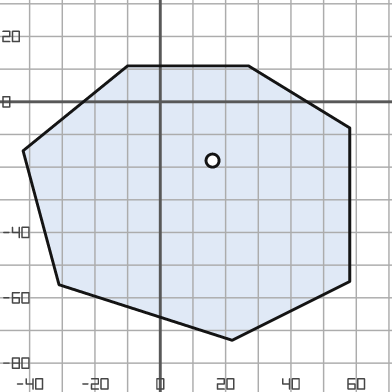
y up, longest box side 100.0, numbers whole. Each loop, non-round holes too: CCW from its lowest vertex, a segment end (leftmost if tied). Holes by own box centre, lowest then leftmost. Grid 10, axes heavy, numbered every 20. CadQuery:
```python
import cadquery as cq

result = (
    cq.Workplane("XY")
    .moveTo(22.0, -73.0)
    .lineTo(58.0, -55.0)
    .lineTo(58.0, -8.0)
    .lineTo(27.0, 11.0)
    .lineTo(-10.0, 11.0)
    .lineTo(-42.0, -15.0)
    .lineTo(-31.0, -56.0)
    .close()
    .moveTo(16.0, -18.0)
    .circle(2.0)
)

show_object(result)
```